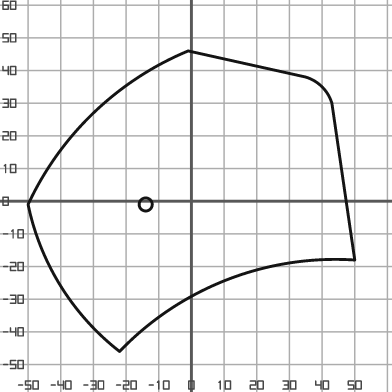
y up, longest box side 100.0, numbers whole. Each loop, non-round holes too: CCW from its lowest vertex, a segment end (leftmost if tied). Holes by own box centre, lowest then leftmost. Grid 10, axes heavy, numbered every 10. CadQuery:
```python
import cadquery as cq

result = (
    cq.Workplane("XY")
    .moveTo(-22.0, -46.0)
    .threePointArc((11.0, -24.0), (50.0, -18.0))
    .lineTo(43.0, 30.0)
    .threePointArc((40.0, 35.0), (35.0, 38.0))
    .lineTo(-1.0, 46.0)
    .threePointArc((-30.0, 27.0), (-50.0, -1.0))
    .threePointArc((-40.0, -26.0), (-22.0, -46.0))
    .close()
    .moveTo(-14.0, -1.0)
    .circle(2.0)
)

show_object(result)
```